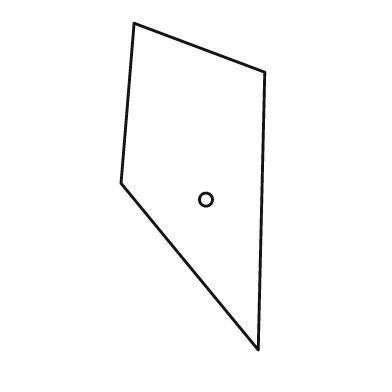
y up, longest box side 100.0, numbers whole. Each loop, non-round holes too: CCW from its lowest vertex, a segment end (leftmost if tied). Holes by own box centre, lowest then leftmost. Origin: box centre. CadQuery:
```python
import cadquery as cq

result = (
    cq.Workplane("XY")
    .moveTo(20.0, -50.0)
    .lineTo(22.0, 35.0)
    .lineTo(-18.0, 50.0)
    .lineTo(-22.0, 1.0)
    .close()
    .moveTo(4.0, -4.0)
    .circle(2.0)
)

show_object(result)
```